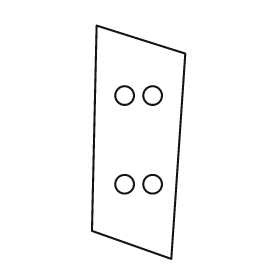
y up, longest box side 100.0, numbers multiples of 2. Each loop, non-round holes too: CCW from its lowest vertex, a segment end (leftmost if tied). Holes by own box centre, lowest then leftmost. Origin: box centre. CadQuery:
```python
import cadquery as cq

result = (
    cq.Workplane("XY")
    .moveTo(14.0, -50.0)
    .lineTo(20.0, 38.0)
    .lineTo(-18.0, 50.0)
    .lineTo(-20.0, -38.0)
    .close()
    .moveTo(-6.0, -18.0)
    .circle(4.0)
    .moveTo(6.0, -18.0)
    .circle(4.0)
    .moveTo(-6.0, 20.0)
    .circle(4.0)
    .moveTo(6.0, 20.0)
    .circle(4.0)
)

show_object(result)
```